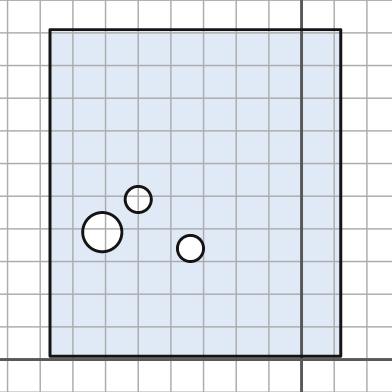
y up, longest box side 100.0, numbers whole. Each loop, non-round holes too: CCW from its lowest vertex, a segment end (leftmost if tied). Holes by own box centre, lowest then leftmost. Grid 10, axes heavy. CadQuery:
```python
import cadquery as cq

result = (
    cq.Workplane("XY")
    .moveTo(-77.0, 1.0)
    .lineTo(12.0, 1.0)
    .lineTo(12.0, 101.0)
    .lineTo(-77.0, 101.0)
    .close()
    .moveTo(-34.0, 34.0)
    .circle(4.0)
    .moveTo(-61.0, 39.0)
    .circle(6.0)
    .moveTo(-50.0, 49.0)
    .circle(4.0)
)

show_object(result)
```